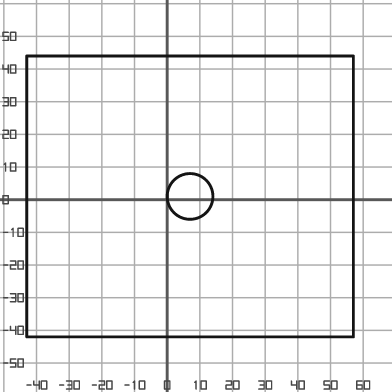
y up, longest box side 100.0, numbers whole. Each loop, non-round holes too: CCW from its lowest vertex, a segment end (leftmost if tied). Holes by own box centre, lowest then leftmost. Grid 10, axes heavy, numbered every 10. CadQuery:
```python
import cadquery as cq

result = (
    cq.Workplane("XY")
    .moveTo(-43.0, -42.0)
    .lineTo(57.0, -42.0)
    .lineTo(57.0, 44.0)
    .lineTo(-43.0, 44.0)
    .close()
    .moveTo(7.0, 1.0)
    .circle(7.0)
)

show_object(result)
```